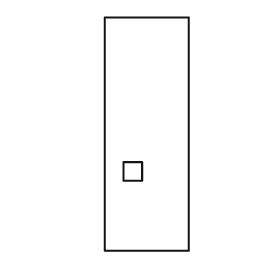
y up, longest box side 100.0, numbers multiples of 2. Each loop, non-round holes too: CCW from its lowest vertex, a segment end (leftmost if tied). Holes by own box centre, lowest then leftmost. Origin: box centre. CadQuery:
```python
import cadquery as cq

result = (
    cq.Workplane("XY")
    .moveTo(-18.0, -50.0)
    .lineTo(18.0, -50.0)
    .lineTo(18.0, 50.0)
    .lineTo(-18.0, 50.0)
    .close()
    .moveTo(-10.0, -20.0)
    .lineTo(-2.0, -20.0)
    .lineTo(-2.0, -12.0)
    .lineTo(-10.0, -12.0)
    .close()
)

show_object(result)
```